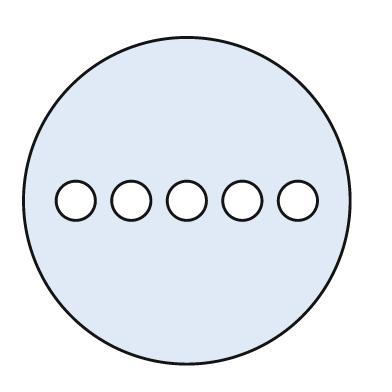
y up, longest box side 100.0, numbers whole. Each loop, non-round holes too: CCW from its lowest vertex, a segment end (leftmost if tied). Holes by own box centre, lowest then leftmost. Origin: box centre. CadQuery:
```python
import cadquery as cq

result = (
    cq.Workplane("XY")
    .moveTo(0.0, 0.0)
    .circle(50.0)
    .moveTo(-34.0, 0.0)
    .circle(6.0)
    .moveTo(-17.0, 0.0)
    .circle(6.0)
    .moveTo(0.0, 0.0)
    .circle(6.0)
    .moveTo(17.0, 0.0)
    .circle(6.0)
    .moveTo(34.0, 0.0)
    .circle(6.0)
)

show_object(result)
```